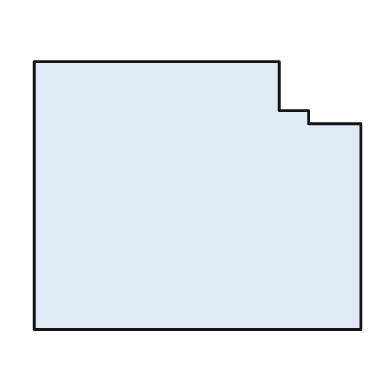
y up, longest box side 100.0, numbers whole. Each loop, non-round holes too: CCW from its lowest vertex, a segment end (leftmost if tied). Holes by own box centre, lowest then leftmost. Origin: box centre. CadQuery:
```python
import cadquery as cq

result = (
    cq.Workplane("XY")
    .moveTo(-50.0, -41.0)
    .lineTo(50.0, -41.0)
    .lineTo(50.0, 22.0)
    .lineTo(34.0, 22.0)
    .lineTo(34.0, 26.0)
    .lineTo(25.0, 26.0)
    .lineTo(25.0, 41.0)
    .lineTo(-50.0, 41.0)
    .close()
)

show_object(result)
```